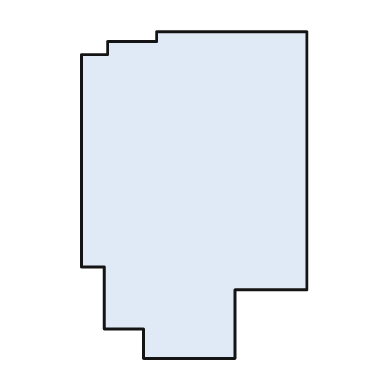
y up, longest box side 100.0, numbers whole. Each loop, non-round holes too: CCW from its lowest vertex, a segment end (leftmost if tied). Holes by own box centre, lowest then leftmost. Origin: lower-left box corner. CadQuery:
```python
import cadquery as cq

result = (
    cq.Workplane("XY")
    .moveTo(19.0, 0.0)
    .lineTo(47.0, 0.0)
    .lineTo(47.0, 21.0)
    .lineTo(69.0, 21.0)
    .lineTo(69.0, 100.0)
    .lineTo(23.0, 100.0)
    .lineTo(23.0, 97.0)
    .lineTo(8.0, 97.0)
    .lineTo(8.0, 93.0)
    .lineTo(0.0, 93.0)
    .lineTo(0.0, 28.0)
    .lineTo(7.0, 28.0)
    .lineTo(7.0, 9.0)
    .lineTo(19.0, 9.0)
    .close()
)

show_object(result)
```